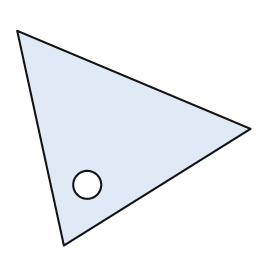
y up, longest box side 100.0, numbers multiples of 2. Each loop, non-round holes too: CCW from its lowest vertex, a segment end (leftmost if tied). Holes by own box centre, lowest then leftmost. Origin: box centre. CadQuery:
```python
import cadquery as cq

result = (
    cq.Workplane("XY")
    .moveTo(-30.0, -46.0)
    .lineTo(50.0, 4.0)
    .lineTo(-50.0, 46.0)
    .close()
    .moveTo(-20.0, -20.0)
    .circle(6.0)
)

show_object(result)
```